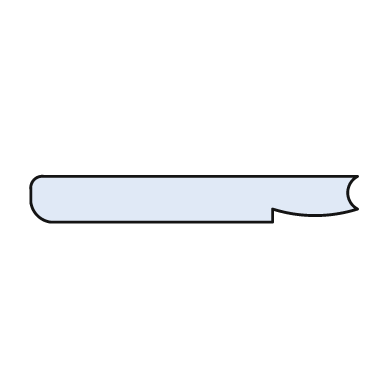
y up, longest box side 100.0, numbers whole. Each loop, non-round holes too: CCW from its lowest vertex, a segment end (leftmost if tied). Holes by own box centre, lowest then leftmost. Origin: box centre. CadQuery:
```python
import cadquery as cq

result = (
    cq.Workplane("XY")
    .moveTo(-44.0, -7.0)
    .lineTo(24.0, -7.0)
    .lineTo(24.0, -3.0)
    .threePointArc((37.0, -5.0), (50.0, -3.0))
    .threePointArc((47.0, 2.0), (50.0, 7.0))
    .lineTo(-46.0, 7.0)
    .threePointArc((-49.0, 6.0), (-50.0, 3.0))
    .lineTo(-50.0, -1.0)
    .threePointArc((-48.0, -5.0), (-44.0, -7.0))
    .close()
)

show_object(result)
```